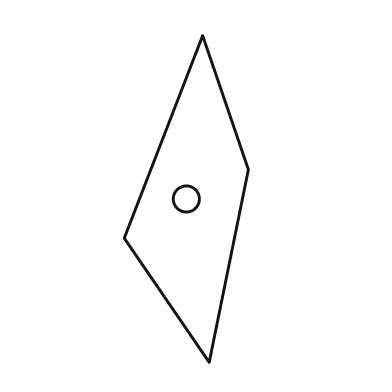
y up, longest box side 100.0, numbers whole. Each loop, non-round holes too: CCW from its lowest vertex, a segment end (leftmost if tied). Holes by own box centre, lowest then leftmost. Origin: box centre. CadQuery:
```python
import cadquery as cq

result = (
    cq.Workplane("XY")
    .moveTo(7.0, -50.0)
    .lineTo(19.0, 9.0)
    .lineTo(5.0, 50.0)
    .lineTo(-19.0, -12.0)
    .close()
    .moveTo(0.0, 0.0)
    .circle(4.0)
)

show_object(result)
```